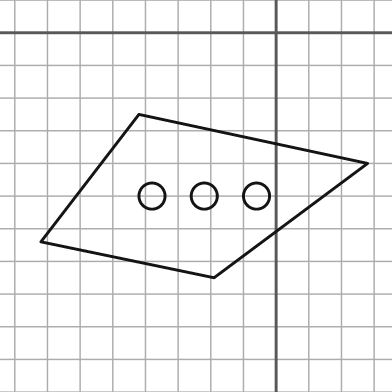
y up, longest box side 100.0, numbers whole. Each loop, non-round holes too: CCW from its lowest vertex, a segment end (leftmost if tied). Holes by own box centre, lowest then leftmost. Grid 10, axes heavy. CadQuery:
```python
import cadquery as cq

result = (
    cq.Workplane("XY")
    .moveTo(-19.0, -75.0)
    .lineTo(28.0, -40.0)
    .lineTo(-42.0, -25.0)
    .lineTo(-72.0, -64.0)
    .close()
    .moveTo(-38.0, -50.0)
    .circle(4.0)
    .moveTo(-22.0, -50.0)
    .circle(4.0)
    .moveTo(-6.0, -50.0)
    .circle(4.0)
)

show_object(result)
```